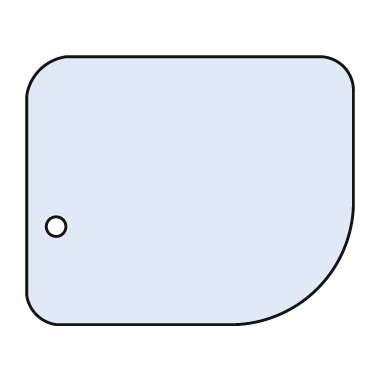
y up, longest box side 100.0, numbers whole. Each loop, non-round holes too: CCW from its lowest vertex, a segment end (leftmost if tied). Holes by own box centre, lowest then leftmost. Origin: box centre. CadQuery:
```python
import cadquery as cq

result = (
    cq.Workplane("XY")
    .moveTo(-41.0, -41.0)
    .lineTo(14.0, -41.0)
    .threePointArc((39.0, -30.0), (50.0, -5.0))
    .lineTo(50.0, 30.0)
    .threePointArc((47.0, 38.0), (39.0, 41.0))
    .lineTo(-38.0, 41.0)
    .threePointArc((-46.0, 37.0), (-50.0, 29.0))
    .lineTo(-50.0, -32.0)
    .threePointArc((-47.0, -38.0), (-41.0, -41.0))
    .close()
    .moveTo(-41.0, -11.0)
    .circle(3.0)
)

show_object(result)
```